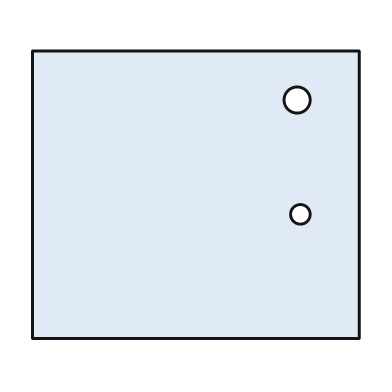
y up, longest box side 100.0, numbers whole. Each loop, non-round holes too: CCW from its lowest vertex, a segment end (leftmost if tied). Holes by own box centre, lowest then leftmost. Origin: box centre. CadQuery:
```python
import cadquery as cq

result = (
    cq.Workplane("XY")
    .moveTo(-50.0, -44.0)
    .lineTo(50.0, -44.0)
    .lineTo(50.0, 44.0)
    .lineTo(-50.0, 44.0)
    .close()
    .moveTo(32.0, -6.0)
    .circle(3.0)
    .moveTo(31.0, 29.0)
    .circle(4.0)
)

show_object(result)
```